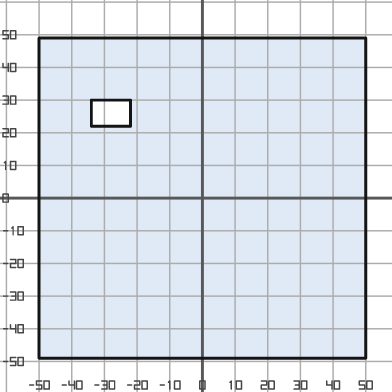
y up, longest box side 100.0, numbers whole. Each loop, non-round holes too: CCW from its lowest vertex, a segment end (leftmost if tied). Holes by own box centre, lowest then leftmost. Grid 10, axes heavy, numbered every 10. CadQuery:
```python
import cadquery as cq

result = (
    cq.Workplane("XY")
    .moveTo(-50.0, -49.0)
    .lineTo(50.0, -49.0)
    .lineTo(50.0, 49.0)
    .lineTo(-50.0, 49.0)
    .close()
    .moveTo(-34.0, 22.0)
    .lineTo(-22.0, 22.0)
    .lineTo(-22.0, 30.0)
    .lineTo(-34.0, 30.0)
    .close()
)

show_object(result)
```